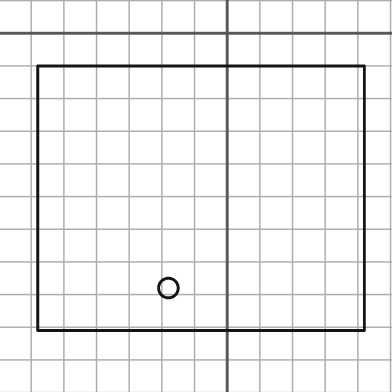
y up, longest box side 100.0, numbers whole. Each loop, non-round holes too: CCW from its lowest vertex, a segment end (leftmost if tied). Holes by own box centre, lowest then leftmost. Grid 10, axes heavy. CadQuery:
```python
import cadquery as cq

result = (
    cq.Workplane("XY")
    .moveTo(-58.0, -91.0)
    .lineTo(42.0, -91.0)
    .lineTo(42.0, -10.0)
    .lineTo(-58.0, -10.0)
    .close()
    .moveTo(-18.0, -78.0)
    .circle(3.0)
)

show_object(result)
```